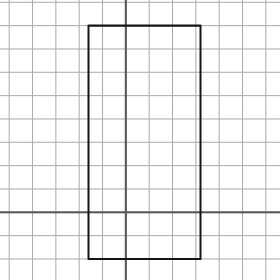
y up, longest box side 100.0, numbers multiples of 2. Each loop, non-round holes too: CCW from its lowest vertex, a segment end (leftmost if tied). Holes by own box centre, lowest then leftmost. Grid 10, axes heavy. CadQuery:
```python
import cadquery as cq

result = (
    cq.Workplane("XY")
    .moveTo(-16.0, -20.0)
    .lineTo(32.0, -20.0)
    .lineTo(32.0, 80.0)
    .lineTo(-16.0, 80.0)
    .close()
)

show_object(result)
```